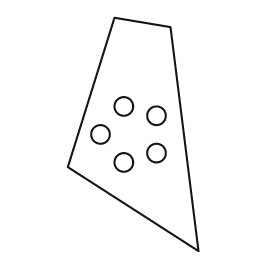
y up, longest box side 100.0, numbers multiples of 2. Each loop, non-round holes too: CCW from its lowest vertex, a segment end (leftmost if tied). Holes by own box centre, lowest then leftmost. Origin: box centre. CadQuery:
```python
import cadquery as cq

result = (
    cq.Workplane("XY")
    .moveTo(28.0, -50.0)
    .lineTo(16.0, 46.0)
    .lineTo(-8.0, 50.0)
    .lineTo(-28.0, -14.0)
    .close()
    .moveTo(-4.0, -12.0)
    .circle(4.0)
    .moveTo(10.0, -8.0)
    .circle(4.0)
    .moveTo(-14.0, 0.0)
    .circle(4.0)
    .moveTo(10.0, 8.0)
    .circle(4.0)
    .moveTo(-4.0, 12.0)
    .circle(4.0)
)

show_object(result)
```